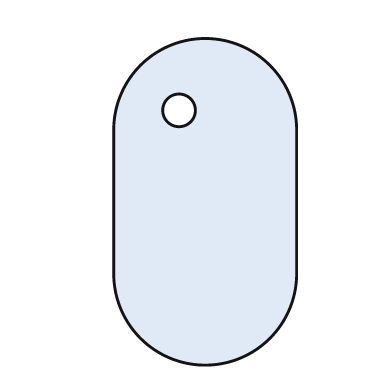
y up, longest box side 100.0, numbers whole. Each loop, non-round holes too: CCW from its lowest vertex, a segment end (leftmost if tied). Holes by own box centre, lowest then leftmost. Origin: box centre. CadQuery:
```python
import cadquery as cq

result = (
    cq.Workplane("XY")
    .moveTo(-28.0, -22.0)
    .threePointArc((0.0, -50.0), (28.0, -22.0))
    .lineTo(28.0, 22.0)
    .threePointArc((0.0, 50.0), (-28.0, 22.0))
    .close()
    .moveTo(-8.0, 28.0)
    .circle(5.0)
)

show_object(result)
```